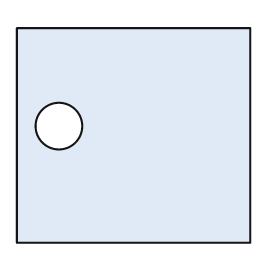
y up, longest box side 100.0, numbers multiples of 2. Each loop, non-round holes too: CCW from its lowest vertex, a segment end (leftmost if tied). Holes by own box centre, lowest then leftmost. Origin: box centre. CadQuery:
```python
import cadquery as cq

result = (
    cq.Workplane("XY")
    .moveTo(-50.0, -46.0)
    .lineTo(50.0, -46.0)
    .lineTo(50.0, 46.0)
    .lineTo(-50.0, 46.0)
    .close()
    .moveTo(-32.0, 4.0)
    .circle(10.0)
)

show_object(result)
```